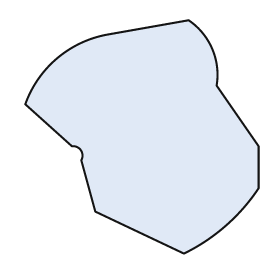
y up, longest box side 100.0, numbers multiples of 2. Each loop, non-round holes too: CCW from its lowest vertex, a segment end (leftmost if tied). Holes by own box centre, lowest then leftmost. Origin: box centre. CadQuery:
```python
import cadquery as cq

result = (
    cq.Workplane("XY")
    .moveTo(18.0, -50.0)
    .threePointArc((36.0, -38.0), (50.0, -22.0))
    .lineTo(50.0, -4.0)
    .lineTo(32.0, 22.0)
    .threePointArc((30.0, 38.0), (20.0, 50.0))
    .lineTo(-14.0, 44.0)
    .threePointArc((-36.0, 34.0), (-50.0, 14.0))
    .lineTo(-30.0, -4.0)
    .threePointArc((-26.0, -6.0), (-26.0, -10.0))
    .lineTo(-20.0, -32.0)
    .close()
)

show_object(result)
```